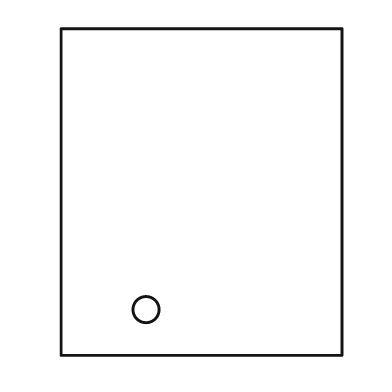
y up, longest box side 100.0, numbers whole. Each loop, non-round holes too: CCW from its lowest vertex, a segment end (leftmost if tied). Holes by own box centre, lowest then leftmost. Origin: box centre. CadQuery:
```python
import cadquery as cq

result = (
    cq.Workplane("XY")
    .moveTo(-43.0, -50.0)
    .lineTo(43.0, -50.0)
    .lineTo(43.0, 50.0)
    .lineTo(-43.0, 50.0)
    .close()
    .moveTo(-17.0, -36.0)
    .circle(4.0)
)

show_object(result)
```